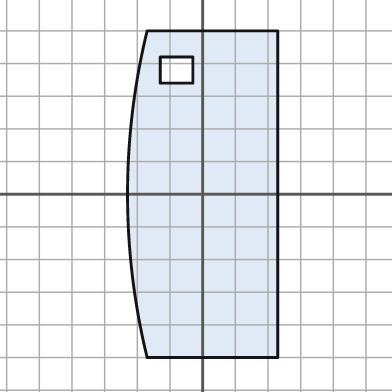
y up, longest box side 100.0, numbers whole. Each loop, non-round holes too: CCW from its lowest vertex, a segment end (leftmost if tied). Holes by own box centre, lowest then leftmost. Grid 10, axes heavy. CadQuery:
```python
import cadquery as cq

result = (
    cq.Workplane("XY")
    .moveTo(-17.0, -50.0)
    .lineTo(23.0, -50.0)
    .lineTo(23.0, 50.0)
    .lineTo(-17.0, 50.0)
    .threePointArc((-23.0, 0.0), (-17.0, -50.0))
    .close()
    .moveTo(-13.0, 34.0)
    .lineTo(-3.0, 34.0)
    .lineTo(-3.0, 42.0)
    .lineTo(-13.0, 42.0)
    .close()
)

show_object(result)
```